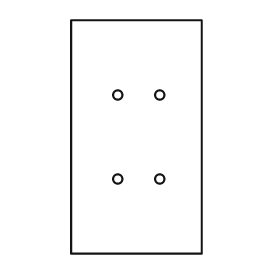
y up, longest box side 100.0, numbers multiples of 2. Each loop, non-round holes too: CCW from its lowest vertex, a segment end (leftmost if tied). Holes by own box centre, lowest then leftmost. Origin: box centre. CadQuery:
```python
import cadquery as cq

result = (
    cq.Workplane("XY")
    .moveTo(-28.0, -50.0)
    .lineTo(28.0, -50.0)
    .lineTo(28.0, 50.0)
    .lineTo(-28.0, 50.0)
    .close()
    .moveTo(-8.0, -18.0)
    .circle(2.0)
    .moveTo(10.0, -18.0)
    .circle(2.0)
    .moveTo(-8.0, 18.0)
    .circle(2.0)
    .moveTo(10.0, 18.0)
    .circle(2.0)
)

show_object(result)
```